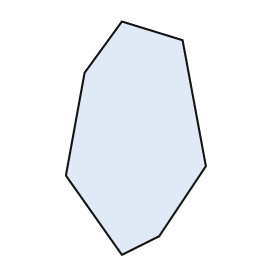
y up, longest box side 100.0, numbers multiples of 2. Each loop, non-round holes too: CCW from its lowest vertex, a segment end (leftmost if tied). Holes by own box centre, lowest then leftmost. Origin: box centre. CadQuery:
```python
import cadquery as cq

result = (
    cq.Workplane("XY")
    .moveTo(-6.0, -50.0)
    .lineTo(10.0, -42.0)
    .lineTo(30.0, -12.0)
    .lineTo(20.0, 42.0)
    .lineTo(-6.0, 50.0)
    .lineTo(-22.0, 28.0)
    .lineTo(-30.0, -16.0)
    .close()
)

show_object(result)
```